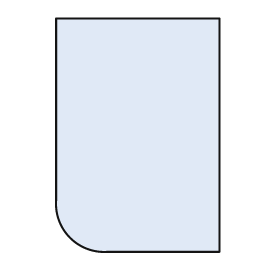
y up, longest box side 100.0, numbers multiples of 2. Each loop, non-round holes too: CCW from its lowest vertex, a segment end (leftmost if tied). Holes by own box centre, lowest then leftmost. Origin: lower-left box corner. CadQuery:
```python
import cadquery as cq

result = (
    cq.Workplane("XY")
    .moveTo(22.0, 0.0)
    .lineTo(70.0, 0.0)
    .lineTo(70.0, 100.0)
    .lineTo(0.0, 100.0)
    .lineTo(0.0, 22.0)
    .threePointArc((6.0, 6.0), (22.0, 0.0))
    .close()
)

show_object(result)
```